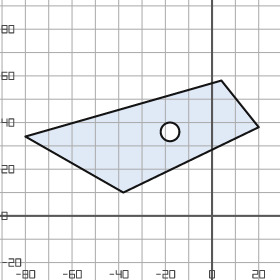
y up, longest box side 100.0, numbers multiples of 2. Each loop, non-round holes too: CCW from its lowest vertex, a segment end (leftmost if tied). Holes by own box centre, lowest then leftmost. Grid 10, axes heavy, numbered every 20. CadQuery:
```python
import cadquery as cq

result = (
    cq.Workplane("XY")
    .moveTo(-38.0, 10.0)
    .lineTo(20.0, 38.0)
    .lineTo(4.0, 58.0)
    .lineTo(-80.0, 34.0)
    .close()
    .moveTo(-18.0, 36.0)
    .circle(4.0)
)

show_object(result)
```